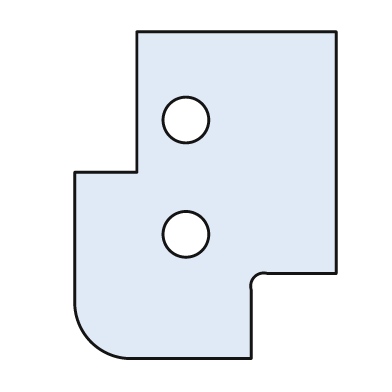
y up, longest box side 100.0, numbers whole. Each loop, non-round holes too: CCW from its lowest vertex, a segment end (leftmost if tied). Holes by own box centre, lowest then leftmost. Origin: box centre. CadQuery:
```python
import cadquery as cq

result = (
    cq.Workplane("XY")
    .moveTo(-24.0, -50.0)
    .lineTo(14.0, -50.0)
    .lineTo(14.0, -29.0)
    .threePointArc((15.0, -25.0), (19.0, -24.0))
    .lineTo(40.0, -24.0)
    .lineTo(40.0, 50.0)
    .lineTo(-21.0, 50.0)
    .lineTo(-21.0, 7.0)
    .lineTo(-40.0, 7.0)
    .lineTo(-40.0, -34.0)
    .threePointArc((-35.0, -45.0), (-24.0, -50.0))
    .close()
    .moveTo(-6.0, -12.0)
    .circle(7.0)
    .moveTo(-6.0, 23.0)
    .circle(7.0)
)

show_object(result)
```